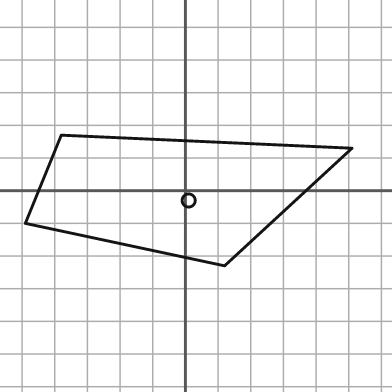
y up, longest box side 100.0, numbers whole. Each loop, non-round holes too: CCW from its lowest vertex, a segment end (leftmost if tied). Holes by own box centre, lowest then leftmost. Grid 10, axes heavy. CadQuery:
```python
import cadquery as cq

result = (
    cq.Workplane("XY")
    .moveTo(12.0, -23.0)
    .lineTo(51.0, 13.0)
    .lineTo(-38.0, 17.0)
    .lineTo(-49.0, -10.0)
    .close()
    .moveTo(1.0, -3.0)
    .circle(2.0)
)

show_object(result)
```